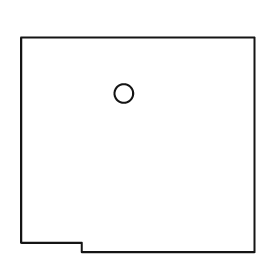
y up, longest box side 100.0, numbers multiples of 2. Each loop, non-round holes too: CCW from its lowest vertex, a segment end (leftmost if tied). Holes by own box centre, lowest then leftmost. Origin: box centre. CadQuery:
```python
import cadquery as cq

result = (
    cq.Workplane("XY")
    .moveTo(-24.0, -46.0)
    .lineTo(50.0, -46.0)
    .lineTo(50.0, 46.0)
    .lineTo(-50.0, 46.0)
    .lineTo(-50.0, -42.0)
    .lineTo(-24.0, -42.0)
    .close()
    .moveTo(-6.0, 22.0)
    .circle(4.0)
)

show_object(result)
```